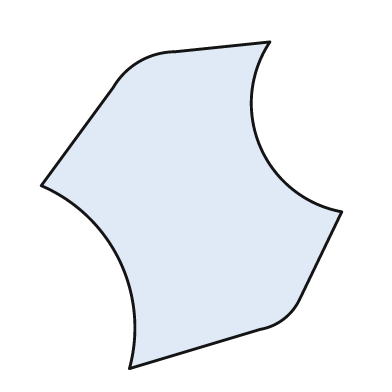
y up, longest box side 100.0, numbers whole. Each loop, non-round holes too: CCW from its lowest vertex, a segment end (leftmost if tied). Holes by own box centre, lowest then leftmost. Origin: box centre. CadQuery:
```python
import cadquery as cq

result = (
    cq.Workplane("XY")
    .moveTo(-19.0, -50.0)
    .lineTo(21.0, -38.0)
    .threePointArc((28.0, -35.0), (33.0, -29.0))
    .lineTo(46.0, -2.0)
    .threePointArc((21.0, 18.0), (24.0, 50.0))
    .lineTo(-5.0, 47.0)
    .threePointArc((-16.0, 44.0), (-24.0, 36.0))
    .lineTo(-46.0, 6.0)
    .threePointArc((-22.0, -17.0), (-19.0, -50.0))
    .close()
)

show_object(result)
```